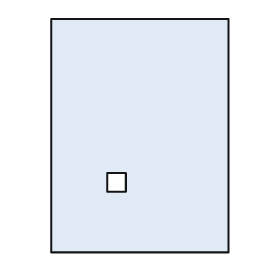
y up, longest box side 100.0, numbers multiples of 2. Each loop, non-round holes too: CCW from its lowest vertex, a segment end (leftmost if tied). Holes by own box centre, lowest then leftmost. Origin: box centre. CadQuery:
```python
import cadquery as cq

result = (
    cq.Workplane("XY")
    .moveTo(-38.0, -50.0)
    .lineTo(38.0, -50.0)
    .lineTo(38.0, 50.0)
    .lineTo(-38.0, 50.0)
    .close()
    .moveTo(-14.0, -24.0)
    .lineTo(-6.0, -24.0)
    .lineTo(-6.0, -16.0)
    .lineTo(-14.0, -16.0)
    .close()
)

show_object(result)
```